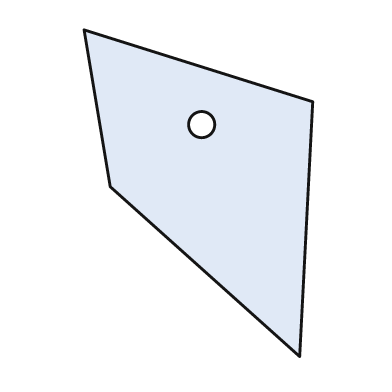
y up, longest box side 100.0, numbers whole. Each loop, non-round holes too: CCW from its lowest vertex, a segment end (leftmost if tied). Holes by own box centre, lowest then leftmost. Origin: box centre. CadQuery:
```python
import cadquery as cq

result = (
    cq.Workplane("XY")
    .moveTo(31.0, -50.0)
    .lineTo(35.0, 28.0)
    .lineTo(-35.0, 50.0)
    .lineTo(-27.0, 2.0)
    .close()
    .moveTo(1.0, 21.0)
    .circle(4.0)
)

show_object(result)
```